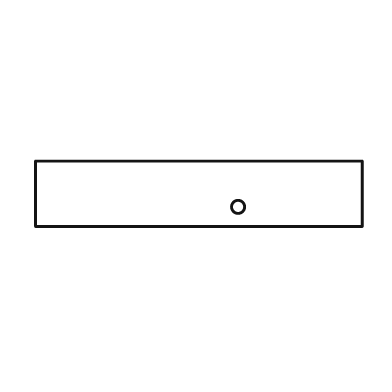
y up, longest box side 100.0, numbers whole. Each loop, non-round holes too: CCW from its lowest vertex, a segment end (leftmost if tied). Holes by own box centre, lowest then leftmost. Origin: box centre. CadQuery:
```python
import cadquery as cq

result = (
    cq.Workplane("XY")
    .moveTo(-50.0, -10.0)
    .lineTo(50.0, -10.0)
    .lineTo(50.0, 10.0)
    .lineTo(-50.0, 10.0)
    .close()
    .moveTo(12.0, -4.0)
    .circle(2.0)
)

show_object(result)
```